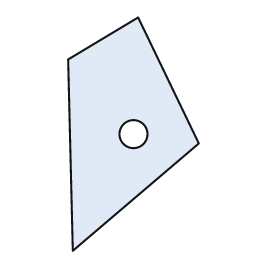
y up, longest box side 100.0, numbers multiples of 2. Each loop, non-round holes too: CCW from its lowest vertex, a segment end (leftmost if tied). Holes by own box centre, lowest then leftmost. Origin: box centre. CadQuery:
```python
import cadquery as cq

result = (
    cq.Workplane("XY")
    .moveTo(-26.0, -50.0)
    .lineTo(28.0, -4.0)
    .lineTo(2.0, 50.0)
    .lineTo(-28.0, 32.0)
    .close()
    .moveTo(0.0, 0.0)
    .circle(6.0)
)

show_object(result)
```